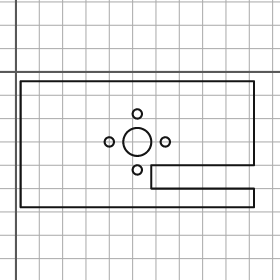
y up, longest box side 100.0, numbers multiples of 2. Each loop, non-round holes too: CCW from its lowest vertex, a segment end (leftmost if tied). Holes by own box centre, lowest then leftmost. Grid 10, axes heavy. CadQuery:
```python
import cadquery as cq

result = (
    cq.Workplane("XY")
    .moveTo(2.0, -58.0)
    .lineTo(102.0, -58.0)
    .lineTo(102.0, -50.0)
    .lineTo(58.0, -50.0)
    .lineTo(58.0, -40.0)
    .lineTo(102.0, -40.0)
    .lineTo(102.0, -4.0)
    .lineTo(2.0, -4.0)
    .close()
    .moveTo(52.0, -42.0)
    .circle(2.0)
    .moveTo(40.0, -30.0)
    .circle(2.0)
    .moveTo(52.0, -30.0)
    .circle(6.0)
    .moveTo(64.0, -30.0)
    .circle(2.0)
    .moveTo(52.0, -18.0)
    .circle(2.0)
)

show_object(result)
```